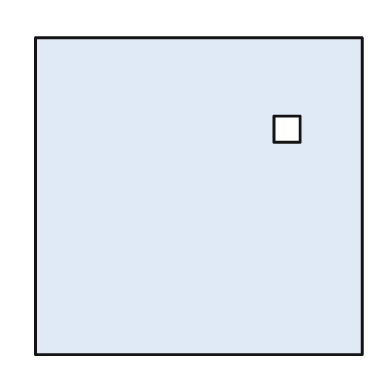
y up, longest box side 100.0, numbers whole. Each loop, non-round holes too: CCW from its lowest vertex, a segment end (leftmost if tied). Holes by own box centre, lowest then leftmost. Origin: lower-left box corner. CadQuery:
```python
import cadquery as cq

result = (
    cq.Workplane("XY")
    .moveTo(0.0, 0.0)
    .lineTo(100.0, 0.0)
    .lineTo(100.0, 97.0)
    .lineTo(0.0, 97.0)
    .close()
    .moveTo(73.0, 65.0)
    .lineTo(81.0, 65.0)
    .lineTo(81.0, 73.0)
    .lineTo(73.0, 73.0)
    .close()
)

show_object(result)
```